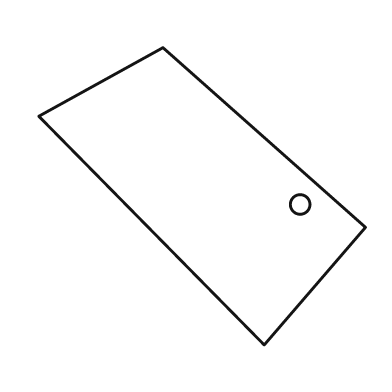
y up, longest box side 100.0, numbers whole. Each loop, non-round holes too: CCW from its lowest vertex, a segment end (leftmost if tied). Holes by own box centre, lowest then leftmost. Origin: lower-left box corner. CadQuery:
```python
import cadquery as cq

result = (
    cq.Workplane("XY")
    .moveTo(69.0, 0.0)
    .lineTo(100.0, 36.0)
    .lineTo(38.0, 91.0)
    .lineTo(0.0, 70.0)
    .close()
    .moveTo(80.0, 43.0)
    .circle(3.0)
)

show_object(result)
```